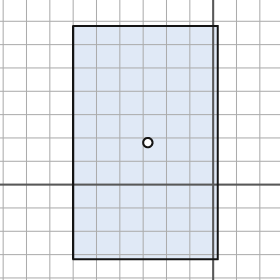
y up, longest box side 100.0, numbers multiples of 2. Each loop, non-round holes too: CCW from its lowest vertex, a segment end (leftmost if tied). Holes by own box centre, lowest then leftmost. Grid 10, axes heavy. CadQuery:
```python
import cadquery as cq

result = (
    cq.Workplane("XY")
    .moveTo(-60.0, -32.0)
    .lineTo(2.0, -32.0)
    .lineTo(2.0, 68.0)
    .lineTo(-60.0, 68.0)
    .close()
    .moveTo(-28.0, 18.0)
    .circle(2.0)
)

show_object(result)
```